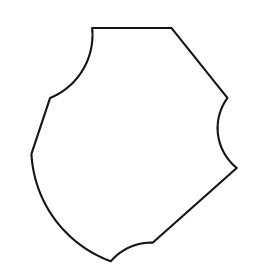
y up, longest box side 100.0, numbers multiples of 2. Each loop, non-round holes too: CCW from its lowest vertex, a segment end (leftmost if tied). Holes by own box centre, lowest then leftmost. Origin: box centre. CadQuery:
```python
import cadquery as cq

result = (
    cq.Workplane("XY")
    .moveTo(-10.0, -50.0)
    .threePointArc((-2.0, -44.0), (8.0, -42.0))
    .lineTo(44.0, -10.0)
    .threePointArc((36.0, 4.0), (40.0, 20.0))
    .lineTo(16.0, 50.0)
    .lineTo(-18.0, 50.0)
    .threePointArc((-22.0, 32.0), (-36.0, 20.0))
    .lineTo(-44.0, -4.0)
    .threePointArc((-34.0, -32.0), (-10.0, -50.0))
    .close()
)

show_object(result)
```